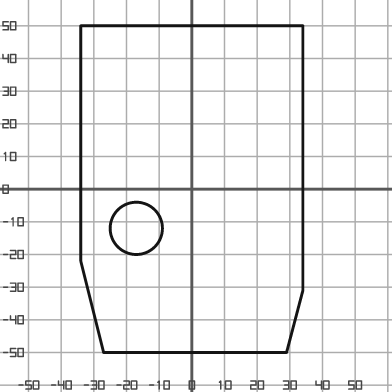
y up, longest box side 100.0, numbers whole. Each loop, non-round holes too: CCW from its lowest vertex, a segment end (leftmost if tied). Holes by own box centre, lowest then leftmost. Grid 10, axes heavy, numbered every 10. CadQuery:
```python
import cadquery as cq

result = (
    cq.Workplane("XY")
    .moveTo(-27.0, -50.0)
    .lineTo(29.0, -50.0)
    .lineTo(34.0, -31.0)
    .lineTo(34.0, 50.0)
    .lineTo(-34.0, 50.0)
    .lineTo(-34.0, -22.0)
    .close()
    .moveTo(-17.0, -12.0)
    .circle(8.0)
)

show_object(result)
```